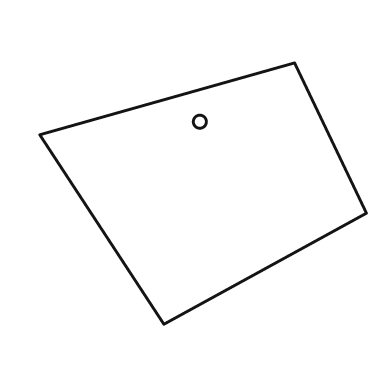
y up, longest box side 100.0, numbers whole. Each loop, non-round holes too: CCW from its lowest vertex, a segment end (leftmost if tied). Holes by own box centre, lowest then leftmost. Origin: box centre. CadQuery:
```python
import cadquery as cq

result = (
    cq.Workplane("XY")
    .moveTo(-12.0, -40.0)
    .lineTo(50.0, -6.0)
    .lineTo(28.0, 40.0)
    .lineTo(-50.0, 18.0)
    .close()
    .moveTo(-1.0, 22.0)
    .circle(2.0)
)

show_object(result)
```